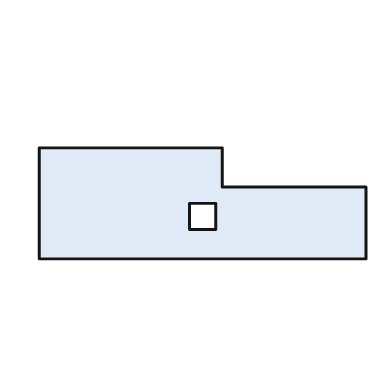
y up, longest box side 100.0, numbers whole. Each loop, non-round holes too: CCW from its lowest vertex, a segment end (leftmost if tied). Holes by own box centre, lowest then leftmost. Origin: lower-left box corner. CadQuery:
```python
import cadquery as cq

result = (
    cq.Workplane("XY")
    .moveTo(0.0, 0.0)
    .lineTo(100.0, 0.0)
    .lineTo(100.0, 22.0)
    .lineTo(56.0, 22.0)
    .lineTo(56.0, 34.0)
    .lineTo(0.0, 34.0)
    .close()
    .moveTo(46.0, 9.0)
    .lineTo(54.0, 9.0)
    .lineTo(54.0, 17.0)
    .lineTo(46.0, 17.0)
    .close()
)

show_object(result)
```